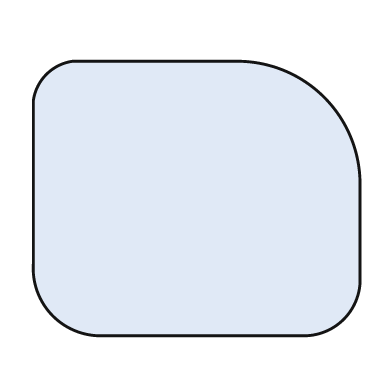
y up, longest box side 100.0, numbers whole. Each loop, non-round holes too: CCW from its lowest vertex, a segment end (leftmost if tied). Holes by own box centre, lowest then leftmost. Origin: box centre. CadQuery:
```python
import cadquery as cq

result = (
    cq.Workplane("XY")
    .moveTo(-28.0, -42.0)
    .lineTo(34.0, -42.0)
    .threePointArc((45.0, -37.0), (50.0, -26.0))
    .lineTo(50.0, 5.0)
    .threePointArc((39.0, 31.0), (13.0, 42.0))
    .lineTo(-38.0, 42.0)
    .threePointArc((-46.0, 38.0), (-50.0, 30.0))
    .lineTo(-50.0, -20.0)
    .threePointArc((-44.0, -36.0), (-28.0, -42.0))
    .close()
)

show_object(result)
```